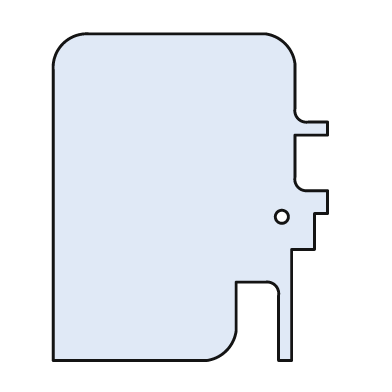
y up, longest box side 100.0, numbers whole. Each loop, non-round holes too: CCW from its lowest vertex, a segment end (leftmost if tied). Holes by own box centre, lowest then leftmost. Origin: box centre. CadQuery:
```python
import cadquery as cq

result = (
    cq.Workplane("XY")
    .moveTo(-42.0, -50.0)
    .lineTo(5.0, -50.0)
    .threePointArc((11.0, -47.0), (14.0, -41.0))
    .lineTo(14.0, -26.0)
    .lineTo(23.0, -26.0)
    .threePointArc((26.0, -27.0), (27.0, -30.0))
    .lineTo(27.0, -50.0)
    .lineTo(31.0, -50.0)
    .lineTo(31.0, -16.0)
    .lineTo(38.0, -16.0)
    .lineTo(38.0, -5.0)
    .lineTo(42.0, -5.0)
    .lineTo(42.0, 2.0)
    .lineTo(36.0, 2.0)
    .threePointArc((33.0, 3.0), (32.0, 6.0))
    .lineTo(32.0, 19.0)
    .lineTo(42.0, 19.0)
    .lineTo(42.0, 23.0)
    .lineTo(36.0, 23.0)
    .threePointArc((33.0, 24.0), (32.0, 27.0))
    .lineTo(32.0, 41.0)
    .threePointArc((29.0, 47.0), (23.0, 50.0))
    .lineTo(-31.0, 50.0)
    .threePointArc((-39.0, 47.0), (-42.0, 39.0))
    .close()
    .moveTo(28.0, -6.0)
    .circle(2.0)
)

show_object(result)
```